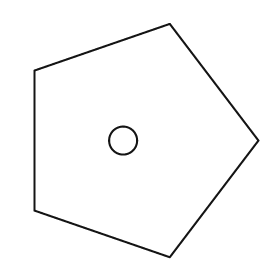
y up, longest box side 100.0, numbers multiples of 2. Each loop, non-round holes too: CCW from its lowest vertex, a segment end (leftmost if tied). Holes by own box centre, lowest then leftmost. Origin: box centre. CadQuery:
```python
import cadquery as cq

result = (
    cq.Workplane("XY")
    .moveTo(10.0, -50.0)
    .lineTo(48.0, 0.0)
    .lineTo(10.0, 50.0)
    .lineTo(-48.0, 30.0)
    .lineTo(-48.0, -30.0)
    .close()
    .moveTo(-10.0, 0.0)
    .circle(6.0)
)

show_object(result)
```